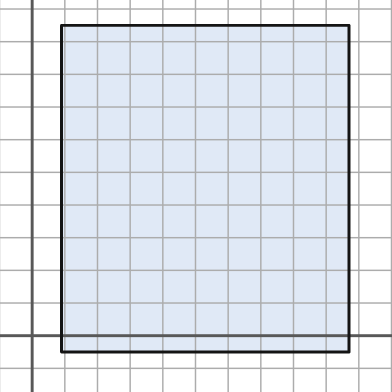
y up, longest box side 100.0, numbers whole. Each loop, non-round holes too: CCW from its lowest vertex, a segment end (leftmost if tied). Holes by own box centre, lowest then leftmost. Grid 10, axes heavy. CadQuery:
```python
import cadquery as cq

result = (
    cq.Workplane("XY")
    .moveTo(9.0, -5.0)
    .lineTo(97.0, -5.0)
    .lineTo(97.0, 95.0)
    .lineTo(9.0, 95.0)
    .close()
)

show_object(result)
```